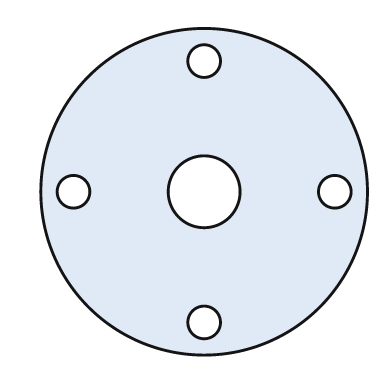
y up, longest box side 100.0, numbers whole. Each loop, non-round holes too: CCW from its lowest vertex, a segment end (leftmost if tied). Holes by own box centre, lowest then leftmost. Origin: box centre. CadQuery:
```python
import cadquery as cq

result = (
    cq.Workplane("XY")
    .moveTo(0.0, 0.0)
    .circle(50.0)
    .moveTo(0.0, -40.0)
    .circle(5.0)
    .moveTo(-40.0, 0.0)
    .circle(5.0)
    .moveTo(0.0, 0.0)
    .circle(11.0)
    .moveTo(40.0, 0.0)
    .circle(5.0)
    .moveTo(0.0, 40.0)
    .circle(5.0)
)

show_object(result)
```